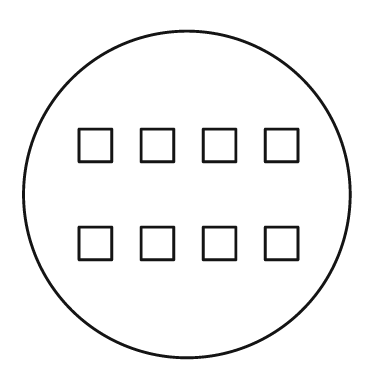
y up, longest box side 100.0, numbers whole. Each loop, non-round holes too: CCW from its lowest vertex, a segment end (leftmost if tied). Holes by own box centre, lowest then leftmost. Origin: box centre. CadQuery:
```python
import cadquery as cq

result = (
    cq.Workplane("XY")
    .moveTo(0.0, 0.0)
    .circle(50.0)
    .moveTo(-33.0, -20.0)
    .lineTo(-23.0, -20.0)
    .lineTo(-23.0, -10.0)
    .lineTo(-33.0, -10.0)
    .close()
    .moveTo(-14.0, -20.0)
    .lineTo(-4.0, -20.0)
    .lineTo(-4.0, -10.0)
    .lineTo(-14.0, -10.0)
    .close()
    .moveTo(5.0, -20.0)
    .lineTo(15.0, -20.0)
    .lineTo(15.0, -10.0)
    .lineTo(5.0, -10.0)
    .close()
    .moveTo(24.0, -20.0)
    .lineTo(34.0, -20.0)
    .lineTo(34.0, -10.0)
    .lineTo(24.0, -10.0)
    .close()
    .moveTo(-33.0, 10.0)
    .lineTo(-23.0, 10.0)
    .lineTo(-23.0, 20.0)
    .lineTo(-33.0, 20.0)
    .close()
    .moveTo(-14.0, 10.0)
    .lineTo(-4.0, 10.0)
    .lineTo(-4.0, 20.0)
    .lineTo(-14.0, 20.0)
    .close()
    .moveTo(5.0, 10.0)
    .lineTo(15.0, 10.0)
    .lineTo(15.0, 20.0)
    .lineTo(5.0, 20.0)
    .close()
    .moveTo(24.0, 10.0)
    .lineTo(34.0, 10.0)
    .lineTo(34.0, 20.0)
    .lineTo(24.0, 20.0)
    .close()
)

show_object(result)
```